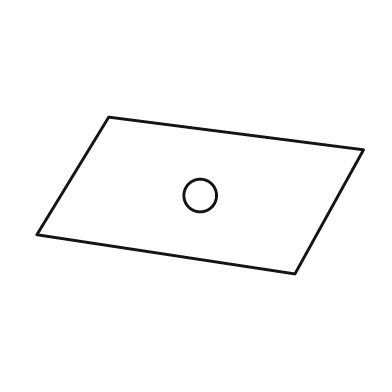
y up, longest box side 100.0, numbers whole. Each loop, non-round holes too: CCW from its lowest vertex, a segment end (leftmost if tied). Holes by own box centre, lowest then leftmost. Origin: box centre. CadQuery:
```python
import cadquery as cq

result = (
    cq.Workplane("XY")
    .moveTo(29.0, -24.0)
    .lineTo(50.0, 14.0)
    .lineTo(-28.0, 24.0)
    .lineTo(-50.0, -12.0)
    .close()
    .moveTo(0.0, 0.0)
    .circle(5.0)
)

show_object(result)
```